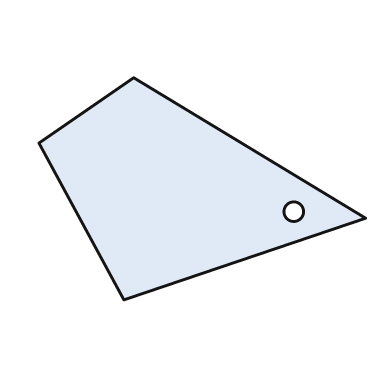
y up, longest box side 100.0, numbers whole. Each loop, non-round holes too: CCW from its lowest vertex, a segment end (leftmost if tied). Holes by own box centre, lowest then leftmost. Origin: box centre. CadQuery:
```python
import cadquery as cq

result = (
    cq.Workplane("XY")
    .moveTo(-24.0, -34.0)
    .lineTo(50.0, -9.0)
    .lineTo(-21.0, 34.0)
    .lineTo(-50.0, 14.0)
    .close()
    .moveTo(28.0, -7.0)
    .circle(3.0)
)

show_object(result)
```